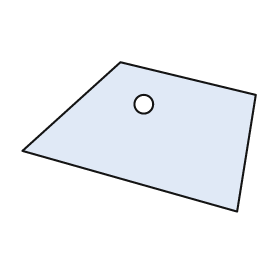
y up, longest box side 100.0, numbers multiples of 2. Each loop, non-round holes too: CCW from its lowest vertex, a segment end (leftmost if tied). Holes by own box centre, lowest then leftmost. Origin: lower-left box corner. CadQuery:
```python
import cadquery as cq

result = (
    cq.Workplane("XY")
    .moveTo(92.0, 0.0)
    .lineTo(100.0, 50.0)
    .lineTo(42.0, 64.0)
    .lineTo(0.0, 26.0)
    .close()
    .moveTo(52.0, 46.0)
    .circle(4.0)
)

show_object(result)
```